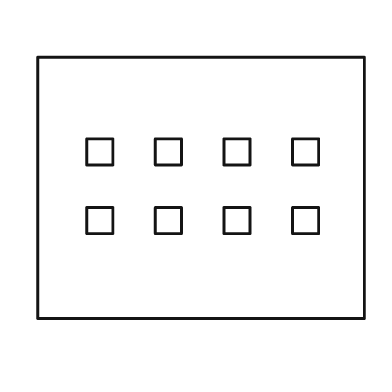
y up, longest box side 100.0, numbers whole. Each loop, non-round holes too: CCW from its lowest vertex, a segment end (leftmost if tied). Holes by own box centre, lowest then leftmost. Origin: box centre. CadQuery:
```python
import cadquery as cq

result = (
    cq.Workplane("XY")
    .moveTo(-50.0, -40.0)
    .lineTo(50.0, -40.0)
    .lineTo(50.0, 40.0)
    .lineTo(-50.0, 40.0)
    .close()
    .moveTo(-35.0, -14.0)
    .lineTo(-27.0, -14.0)
    .lineTo(-27.0, -6.0)
    .lineTo(-35.0, -6.0)
    .close()
    .moveTo(-14.0, -14.0)
    .lineTo(-6.0, -14.0)
    .lineTo(-6.0, -6.0)
    .lineTo(-14.0, -6.0)
    .close()
    .moveTo(7.0, -14.0)
    .lineTo(15.0, -14.0)
    .lineTo(15.0, -6.0)
    .lineTo(7.0, -6.0)
    .close()
    .moveTo(28.0, -14.0)
    .lineTo(36.0, -14.0)
    .lineTo(36.0, -6.0)
    .lineTo(28.0, -6.0)
    .close()
    .moveTo(-35.0, 7.0)
    .lineTo(-27.0, 7.0)
    .lineTo(-27.0, 15.0)
    .lineTo(-35.0, 15.0)
    .close()
    .moveTo(-14.0, 7.0)
    .lineTo(-6.0, 7.0)
    .lineTo(-6.0, 15.0)
    .lineTo(-14.0, 15.0)
    .close()
    .moveTo(7.0, 7.0)
    .lineTo(15.0, 7.0)
    .lineTo(15.0, 15.0)
    .lineTo(7.0, 15.0)
    .close()
    .moveTo(28.0, 7.0)
    .lineTo(36.0, 7.0)
    .lineTo(36.0, 15.0)
    .lineTo(28.0, 15.0)
    .close()
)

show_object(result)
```